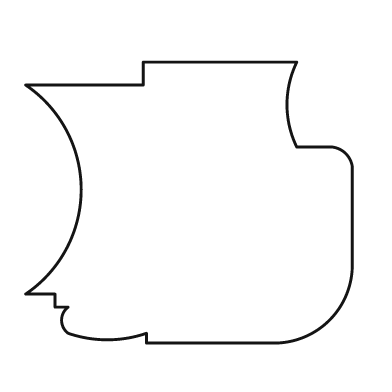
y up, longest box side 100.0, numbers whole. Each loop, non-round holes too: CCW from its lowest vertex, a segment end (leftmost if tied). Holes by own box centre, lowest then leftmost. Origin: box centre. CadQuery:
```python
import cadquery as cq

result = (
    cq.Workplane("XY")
    .moveTo(-13.0, -43.0)
    .lineTo(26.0, -43.0)
    .threePointArc((43.0, -36.0), (50.0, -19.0))
    .lineTo(50.0, 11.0)
    .threePointArc((48.0, 15.0), (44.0, 17.0))
    .lineTo(33.0, 17.0)
    .threePointArc((30.0, 30.0), (33.0, 43.0))
    .lineTo(-14.0, 43.0)
    .lineTo(-14.0, 36.0)
    .lineTo(-50.0, 36.0)
    .threePointArc((-33.0, 4.0), (-50.0, -28.0))
    .lineTo(-41.0, -28.0)
    .lineTo(-41.0, -32.0)
    .lineTo(-37.0, -32.0)
    .threePointArc((-39.0, -36.0), (-37.0, -40.0))
    .threePointArc((-25.0, -42.0), (-13.0, -40.0))
    .close()
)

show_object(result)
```